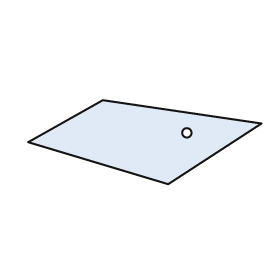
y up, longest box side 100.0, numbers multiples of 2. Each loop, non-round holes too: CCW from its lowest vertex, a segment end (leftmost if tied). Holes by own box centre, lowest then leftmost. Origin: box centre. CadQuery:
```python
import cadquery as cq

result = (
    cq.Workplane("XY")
    .moveTo(10.0, -18.0)
    .lineTo(50.0, 8.0)
    .lineTo(-18.0, 18.0)
    .lineTo(-50.0, 0.0)
    .close()
    .moveTo(18.0, 4.0)
    .circle(2.0)
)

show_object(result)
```